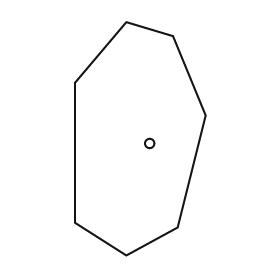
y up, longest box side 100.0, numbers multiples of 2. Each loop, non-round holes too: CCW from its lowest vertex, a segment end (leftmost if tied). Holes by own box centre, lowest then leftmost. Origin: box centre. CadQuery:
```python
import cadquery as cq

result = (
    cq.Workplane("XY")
    .moveTo(-6.0, -50.0)
    .lineTo(16.0, -38.0)
    .lineTo(28.0, 10.0)
    .lineTo(14.0, 44.0)
    .lineTo(-6.0, 50.0)
    .lineTo(-28.0, 24.0)
    .lineTo(-28.0, -36.0)
    .close()
    .moveTo(4.0, -2.0)
    .circle(2.0)
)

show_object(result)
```